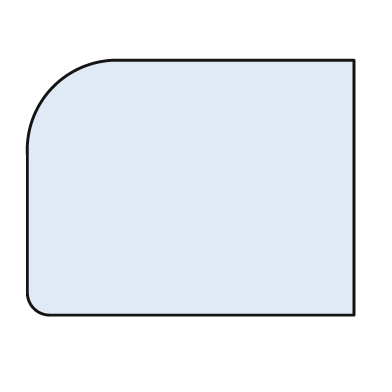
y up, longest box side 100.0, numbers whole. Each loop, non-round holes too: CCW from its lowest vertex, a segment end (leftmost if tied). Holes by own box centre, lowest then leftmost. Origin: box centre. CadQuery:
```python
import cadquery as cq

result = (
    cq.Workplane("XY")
    .moveTo(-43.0, -39.0)
    .lineTo(50.0, -39.0)
    .lineTo(50.0, 39.0)
    .lineTo(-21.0, 39.0)
    .threePointArc((-42.0, 31.0), (-50.0, 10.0))
    .lineTo(-50.0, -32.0)
    .threePointArc((-48.0, -37.0), (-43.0, -39.0))
    .close()
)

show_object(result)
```